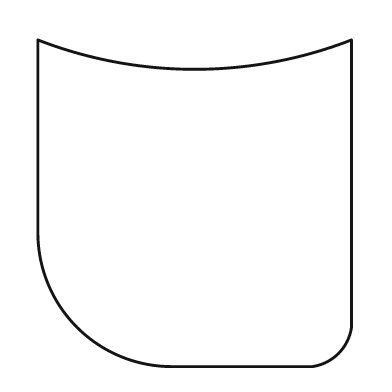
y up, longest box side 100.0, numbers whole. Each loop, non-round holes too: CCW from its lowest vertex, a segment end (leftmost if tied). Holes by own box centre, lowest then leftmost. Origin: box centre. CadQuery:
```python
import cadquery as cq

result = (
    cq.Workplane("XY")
    .moveTo(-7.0, -50.0)
    .lineTo(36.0, -50.0)
    .threePointArc((44.0, -46.0), (48.0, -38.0))
    .lineTo(48.0, 50.0)
    .threePointArc((0.0, 41.0), (-48.0, 50.0))
    .lineTo(-48.0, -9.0)
    .threePointArc((-36.0, -38.0), (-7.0, -50.0))
    .close()
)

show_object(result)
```